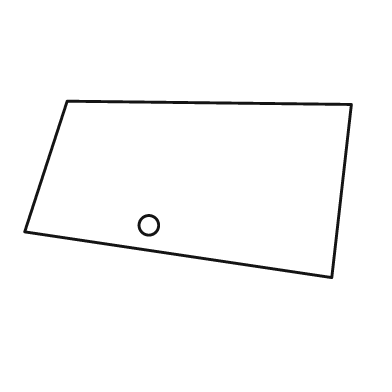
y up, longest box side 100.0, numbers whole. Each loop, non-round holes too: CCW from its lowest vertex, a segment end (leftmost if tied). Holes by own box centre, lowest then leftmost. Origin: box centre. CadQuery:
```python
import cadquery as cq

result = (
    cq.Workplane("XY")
    .moveTo(44.0, -27.0)
    .lineTo(50.0, 26.0)
    .lineTo(-37.0, 27.0)
    .lineTo(-50.0, -13.0)
    .close()
    .moveTo(-12.0, -11.0)
    .circle(3.0)
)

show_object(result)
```